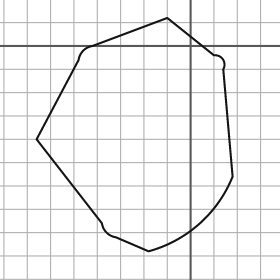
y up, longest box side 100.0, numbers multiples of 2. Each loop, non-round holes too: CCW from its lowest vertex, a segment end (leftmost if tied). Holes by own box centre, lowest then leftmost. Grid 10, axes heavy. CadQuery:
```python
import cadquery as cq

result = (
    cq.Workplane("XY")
    .moveTo(-18.0, -88.0)
    .threePointArc((4.0, -76.0), (18.0, -56.0))
    .lineTo(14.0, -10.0)
    .threePointArc((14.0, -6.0), (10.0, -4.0))
    .lineTo(-10.0, 12.0)
    .lineTo(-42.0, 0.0)
    .threePointArc((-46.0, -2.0), (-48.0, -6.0))
    .lineTo(-66.0, -40.0)
    .lineTo(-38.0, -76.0)
    .threePointArc((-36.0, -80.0), (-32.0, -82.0))
    .close()
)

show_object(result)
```